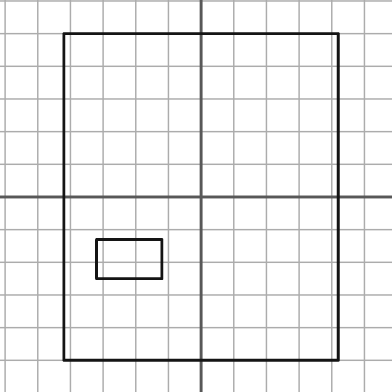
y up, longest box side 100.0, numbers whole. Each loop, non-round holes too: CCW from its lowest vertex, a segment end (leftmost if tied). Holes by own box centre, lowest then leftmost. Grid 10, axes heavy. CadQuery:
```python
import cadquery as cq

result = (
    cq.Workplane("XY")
    .moveTo(-42.0, -50.0)
    .lineTo(42.0, -50.0)
    .lineTo(42.0, 50.0)
    .lineTo(-42.0, 50.0)
    .close()
    .moveTo(-32.0, -25.0)
    .lineTo(-12.0, -25.0)
    .lineTo(-12.0, -13.0)
    .lineTo(-32.0, -13.0)
    .close()
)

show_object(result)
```